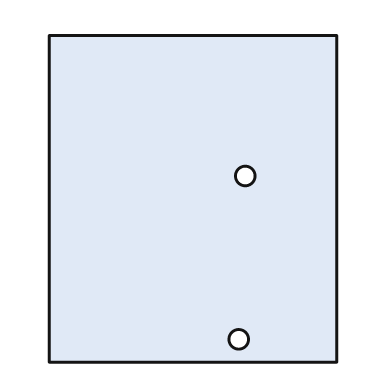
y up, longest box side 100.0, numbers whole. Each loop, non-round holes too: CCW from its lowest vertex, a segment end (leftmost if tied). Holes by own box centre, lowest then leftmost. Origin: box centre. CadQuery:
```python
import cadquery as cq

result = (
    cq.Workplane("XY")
    .moveTo(-44.0, -50.0)
    .lineTo(44.0, -50.0)
    .lineTo(44.0, 50.0)
    .lineTo(-44.0, 50.0)
    .close()
    .moveTo(14.0, -43.0)
    .circle(3.0)
    .moveTo(16.0, 7.0)
    .circle(3.0)
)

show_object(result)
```